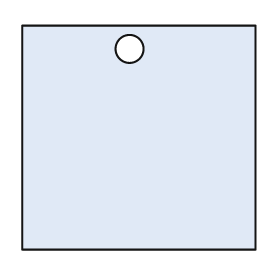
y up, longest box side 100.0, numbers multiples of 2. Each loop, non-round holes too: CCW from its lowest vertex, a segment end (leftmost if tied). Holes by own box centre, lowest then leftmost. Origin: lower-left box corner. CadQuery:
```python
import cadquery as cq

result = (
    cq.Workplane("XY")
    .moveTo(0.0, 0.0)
    .lineTo(100.0, 0.0)
    .lineTo(100.0, 96.0)
    .lineTo(0.0, 96.0)
    .close()
    .moveTo(46.0, 86.0)
    .circle(6.0)
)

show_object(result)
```